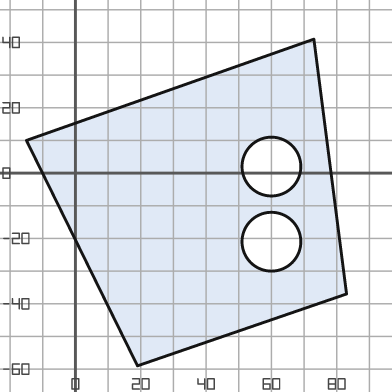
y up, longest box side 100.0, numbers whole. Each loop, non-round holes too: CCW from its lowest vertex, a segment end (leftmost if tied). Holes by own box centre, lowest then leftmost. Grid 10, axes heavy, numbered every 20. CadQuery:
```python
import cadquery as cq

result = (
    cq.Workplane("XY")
    .moveTo(19.0, -59.0)
    .lineTo(83.0, -37.0)
    .lineTo(73.0, 41.0)
    .lineTo(-15.0, 10.0)
    .close()
    .moveTo(60.0, -21.0)
    .circle(9.0)
    .moveTo(60.0, 2.0)
    .circle(9.0)
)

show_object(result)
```